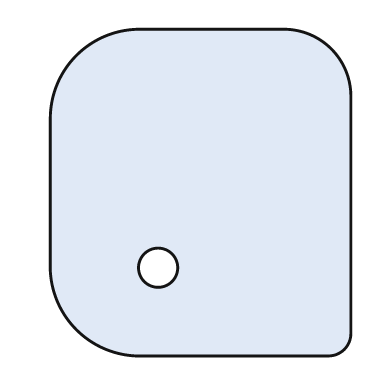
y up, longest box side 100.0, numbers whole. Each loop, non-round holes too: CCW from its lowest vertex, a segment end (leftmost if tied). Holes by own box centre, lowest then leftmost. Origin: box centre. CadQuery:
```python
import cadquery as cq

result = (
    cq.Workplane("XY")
    .moveTo(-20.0, -50.0)
    .lineTo(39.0, -50.0)
    .threePointArc((44.0, -48.0), (46.0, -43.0))
    .lineTo(46.0, 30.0)
    .threePointArc((40.0, 44.0), (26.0, 50.0))
    .lineTo(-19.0, 50.0)
    .threePointArc((-38.0, 42.0), (-46.0, 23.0))
    .lineTo(-46.0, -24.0)
    .threePointArc((-38.0, -42.0), (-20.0, -50.0))
    .close()
    .moveTo(-13.0, -23.0)
    .circle(6.0)
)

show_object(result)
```